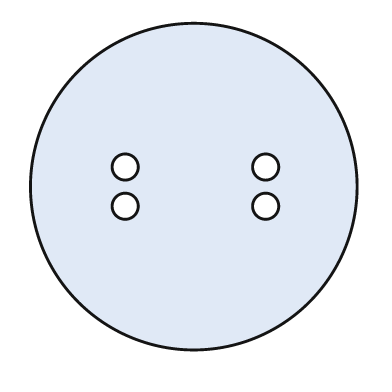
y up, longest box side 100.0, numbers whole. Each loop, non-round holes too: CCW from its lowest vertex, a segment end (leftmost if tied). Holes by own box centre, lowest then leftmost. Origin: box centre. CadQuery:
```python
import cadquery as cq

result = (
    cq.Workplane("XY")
    .moveTo(0.0, 0.0)
    .circle(50.0)
    .moveTo(-21.0, -6.0)
    .circle(4.0)
    .moveTo(22.0, -6.0)
    .circle(4.0)
    .moveTo(-21.0, 6.0)
    .circle(4.0)
    .moveTo(22.0, 6.0)
    .circle(4.0)
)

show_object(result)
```